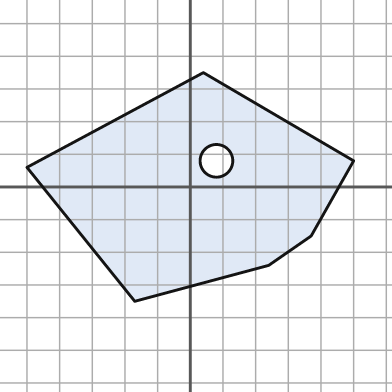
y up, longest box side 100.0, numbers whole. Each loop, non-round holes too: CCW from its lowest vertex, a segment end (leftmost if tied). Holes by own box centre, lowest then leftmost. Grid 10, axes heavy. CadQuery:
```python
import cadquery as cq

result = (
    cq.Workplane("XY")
    .moveTo(-17.0, -35.0)
    .lineTo(24.0, -24.0)
    .lineTo(37.0, -15.0)
    .lineTo(50.0, 8.0)
    .lineTo(4.0, 35.0)
    .lineTo(-50.0, 6.0)
    .close()
    .moveTo(8.0, 8.0)
    .circle(5.0)
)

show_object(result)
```